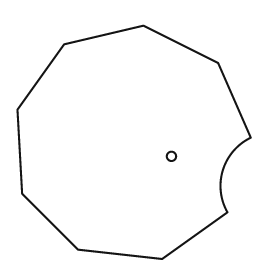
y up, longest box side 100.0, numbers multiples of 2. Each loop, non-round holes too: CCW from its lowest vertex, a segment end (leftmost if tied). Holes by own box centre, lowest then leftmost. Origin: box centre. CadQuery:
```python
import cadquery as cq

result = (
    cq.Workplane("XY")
    .moveTo(12.0, -50.0)
    .lineTo(40.0, -30.0)
    .threePointArc((38.0, -12.0), (50.0, 2.0))
    .lineTo(36.0, 34.0)
    .lineTo(4.0, 50.0)
    .lineTo(-30.0, 42.0)
    .lineTo(-50.0, 14.0)
    .lineTo(-48.0, -22.0)
    .lineTo(-24.0, -46.0)
    .close()
    .moveTo(16.0, -6.0)
    .circle(2.0)
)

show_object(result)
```